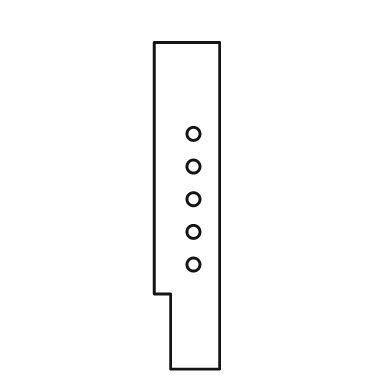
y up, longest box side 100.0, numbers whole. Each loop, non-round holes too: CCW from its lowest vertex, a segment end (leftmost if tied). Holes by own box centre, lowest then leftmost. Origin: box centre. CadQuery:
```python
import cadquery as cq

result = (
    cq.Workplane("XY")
    .moveTo(-5.0, -50.0)
    .lineTo(10.0, -50.0)
    .lineTo(10.0, 50.0)
    .lineTo(-10.0, 50.0)
    .lineTo(-10.0, -27.0)
    .lineTo(-5.0, -27.0)
    .close()
    .moveTo(2.0, -18.0)
    .circle(2.0)
    .moveTo(2.0, -8.0)
    .circle(2.0)
    .moveTo(2.0, 2.0)
    .circle(2.0)
    .moveTo(2.0, 12.0)
    .circle(2.0)
    .moveTo(2.0, 22.0)
    .circle(2.0)
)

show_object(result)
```